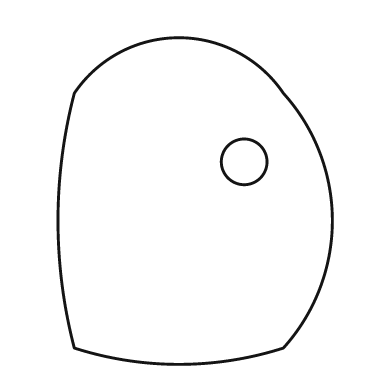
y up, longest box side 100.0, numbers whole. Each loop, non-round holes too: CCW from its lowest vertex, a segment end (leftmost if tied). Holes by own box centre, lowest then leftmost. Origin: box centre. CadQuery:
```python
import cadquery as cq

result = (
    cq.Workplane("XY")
    .moveTo(-37.0, -45.0)
    .threePointArc((-5.0, -50.0), (27.0, -45.0))
    .threePointArc((42.0, -6.0), (27.0, 33.0))
    .threePointArc((-5.0, 50.0), (-37.0, 33.0))
    .threePointArc((-42.0, -6.0), (-37.0, -45.0))
    .close()
    .moveTo(15.0, 12.0)
    .circle(7.0)
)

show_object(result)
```